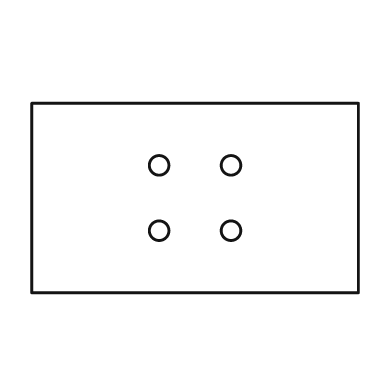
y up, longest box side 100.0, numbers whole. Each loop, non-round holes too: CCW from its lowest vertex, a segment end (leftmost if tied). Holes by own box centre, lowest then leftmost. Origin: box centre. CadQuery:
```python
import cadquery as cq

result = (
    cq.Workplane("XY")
    .moveTo(-50.0, -29.0)
    .lineTo(50.0, -29.0)
    .lineTo(50.0, 29.0)
    .lineTo(-50.0, 29.0)
    .close()
    .moveTo(-11.0, -10.0)
    .circle(3.0)
    .moveTo(11.0, -10.0)
    .circle(3.0)
    .moveTo(-11.0, 10.0)
    .circle(3.0)
    .moveTo(11.0, 10.0)
    .circle(3.0)
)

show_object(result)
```